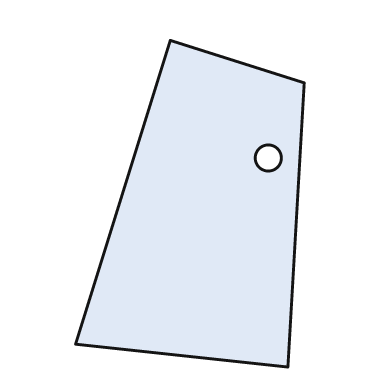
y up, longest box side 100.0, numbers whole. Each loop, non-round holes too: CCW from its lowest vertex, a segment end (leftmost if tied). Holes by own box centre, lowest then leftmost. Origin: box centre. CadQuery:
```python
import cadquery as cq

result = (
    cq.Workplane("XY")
    .moveTo(30.0, -50.0)
    .lineTo(35.0, 37.0)
    .lineTo(-6.0, 50.0)
    .lineTo(-35.0, -43.0)
    .close()
    .moveTo(24.0, 14.0)
    .circle(4.0)
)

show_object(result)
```